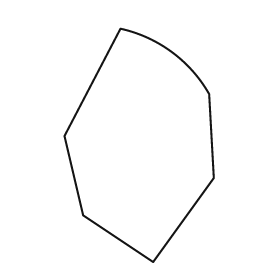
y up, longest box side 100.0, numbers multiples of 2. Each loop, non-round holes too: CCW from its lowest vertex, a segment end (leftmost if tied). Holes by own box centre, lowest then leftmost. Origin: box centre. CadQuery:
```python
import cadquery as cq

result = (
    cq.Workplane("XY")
    .moveTo(6.0, -50.0)
    .lineTo(32.0, -14.0)
    .lineTo(30.0, 22.0)
    .threePointArc((14.0, 40.0), (-8.0, 50.0))
    .lineTo(-32.0, 4.0)
    .lineTo(-24.0, -30.0)
    .close()
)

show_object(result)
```